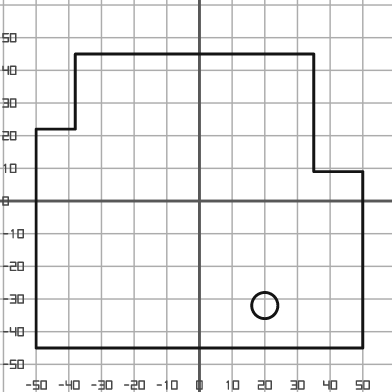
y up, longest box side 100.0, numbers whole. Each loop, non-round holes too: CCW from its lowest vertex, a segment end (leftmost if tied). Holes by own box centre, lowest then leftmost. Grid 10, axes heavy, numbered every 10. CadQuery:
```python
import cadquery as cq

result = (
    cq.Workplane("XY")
    .moveTo(-50.0, -45.0)
    .lineTo(50.0, -45.0)
    .lineTo(50.0, 9.0)
    .lineTo(35.0, 9.0)
    .lineTo(35.0, 45.0)
    .lineTo(-38.0, 45.0)
    .lineTo(-38.0, 22.0)
    .lineTo(-50.0, 22.0)
    .close()
    .moveTo(20.0, -32.0)
    .circle(4.0)
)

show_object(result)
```